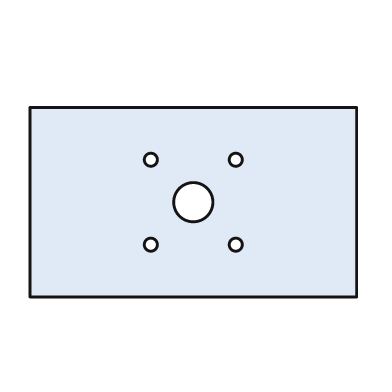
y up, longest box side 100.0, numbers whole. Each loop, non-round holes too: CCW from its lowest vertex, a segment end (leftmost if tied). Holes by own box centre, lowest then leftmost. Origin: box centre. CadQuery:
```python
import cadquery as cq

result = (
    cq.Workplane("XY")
    .moveTo(-50.0, -29.0)
    .lineTo(50.0, -29.0)
    .lineTo(50.0, 29.0)
    .lineTo(-50.0, 29.0)
    .close()
    .moveTo(-13.0, -13.0)
    .circle(2.0)
    .moveTo(13.0, -13.0)
    .circle(2.0)
    .moveTo(0.0, 0.0)
    .circle(6.0)
    .moveTo(-13.0, 13.0)
    .circle(2.0)
    .moveTo(13.0, 13.0)
    .circle(2.0)
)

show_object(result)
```